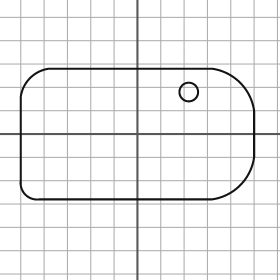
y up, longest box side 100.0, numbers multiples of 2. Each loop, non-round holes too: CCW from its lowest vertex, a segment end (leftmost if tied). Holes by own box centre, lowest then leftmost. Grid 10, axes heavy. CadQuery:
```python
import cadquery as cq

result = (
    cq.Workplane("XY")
    .moveTo(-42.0, -28.0)
    .lineTo(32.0, -28.0)
    .threePointArc((44.0, -22.0), (50.0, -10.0))
    .lineTo(50.0, 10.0)
    .threePointArc((44.0, 22.0), (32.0, 28.0))
    .lineTo(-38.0, 28.0)
    .threePointArc((-46.0, 24.0), (-50.0, 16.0))
    .lineTo(-50.0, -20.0)
    .threePointArc((-48.0, -26.0), (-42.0, -28.0))
    .close()
    .moveTo(22.0, 18.0)
    .circle(4.0)
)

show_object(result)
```